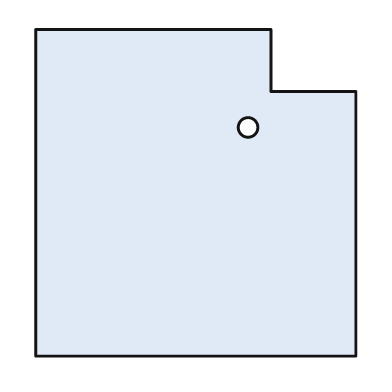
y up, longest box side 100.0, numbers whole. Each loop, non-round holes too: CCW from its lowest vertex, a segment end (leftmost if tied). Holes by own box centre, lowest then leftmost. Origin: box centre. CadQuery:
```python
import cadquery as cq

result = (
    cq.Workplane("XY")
    .moveTo(-49.0, -50.0)
    .lineTo(49.0, -50.0)
    .lineTo(49.0, 31.0)
    .lineTo(23.0, 31.0)
    .lineTo(23.0, 50.0)
    .lineTo(-49.0, 50.0)
    .close()
    .moveTo(16.0, 20.0)
    .circle(3.0)
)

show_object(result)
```